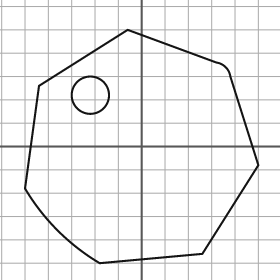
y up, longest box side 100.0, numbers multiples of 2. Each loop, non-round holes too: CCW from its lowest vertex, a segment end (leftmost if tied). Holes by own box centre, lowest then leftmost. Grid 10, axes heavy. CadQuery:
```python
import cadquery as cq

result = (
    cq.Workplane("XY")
    .moveTo(-18.0, -50.0)
    .lineTo(26.0, -46.0)
    .lineTo(50.0, -8.0)
    .lineTo(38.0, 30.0)
    .threePointArc((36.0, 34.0), (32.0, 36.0))
    .lineTo(-6.0, 50.0)
    .lineTo(-44.0, 26.0)
    .lineTo(-50.0, -18.0)
    .threePointArc((-36.0, -36.0), (-18.0, -50.0))
    .close()
    .moveTo(-22.0, 22.0)
    .circle(8.0)
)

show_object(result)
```